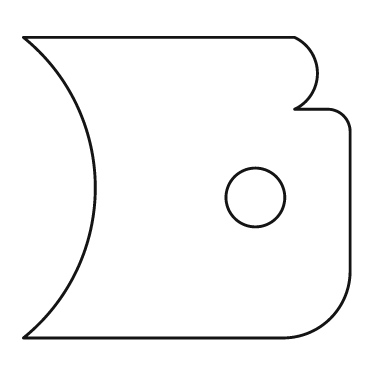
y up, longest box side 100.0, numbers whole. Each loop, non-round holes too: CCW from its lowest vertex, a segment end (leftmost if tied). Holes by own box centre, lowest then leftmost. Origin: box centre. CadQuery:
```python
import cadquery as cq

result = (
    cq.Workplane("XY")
    .moveTo(-50.0, -46.0)
    .lineTo(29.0, -46.0)
    .threePointArc((44.0, -40.0), (50.0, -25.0))
    .lineTo(50.0, 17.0)
    .threePointArc((48.0, 22.0), (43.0, 24.0))
    .lineTo(33.0, 24.0)
    .threePointArc((40.0, 35.0), (33.0, 46.0))
    .lineTo(-50.0, 46.0)
    .threePointArc((-28.0, 0.0), (-50.0, -46.0))
    .close()
    .moveTo(21.0, -3.0)
    .circle(9.0)
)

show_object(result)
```